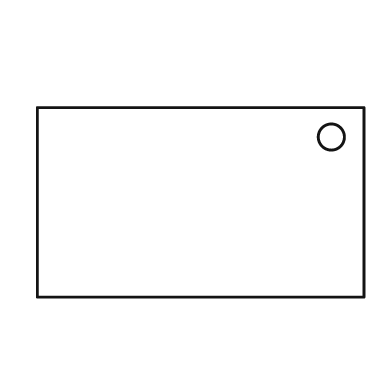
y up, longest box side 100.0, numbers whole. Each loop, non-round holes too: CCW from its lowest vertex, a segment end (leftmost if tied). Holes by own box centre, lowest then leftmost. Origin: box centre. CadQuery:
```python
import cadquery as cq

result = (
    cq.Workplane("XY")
    .moveTo(-50.0, -29.0)
    .lineTo(50.0, -29.0)
    .lineTo(50.0, 29.0)
    .lineTo(-50.0, 29.0)
    .close()
    .moveTo(40.0, 20.0)
    .circle(4.0)
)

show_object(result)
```